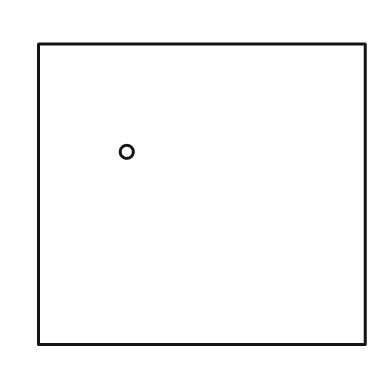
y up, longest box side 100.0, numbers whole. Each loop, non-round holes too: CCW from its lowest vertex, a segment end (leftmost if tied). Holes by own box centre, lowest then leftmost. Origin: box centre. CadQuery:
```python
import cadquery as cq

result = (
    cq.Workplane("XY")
    .moveTo(-50.0, -46.0)
    .lineTo(50.0, -46.0)
    .lineTo(50.0, 46.0)
    .lineTo(-50.0, 46.0)
    .close()
    .moveTo(-23.0, 13.0)
    .circle(2.0)
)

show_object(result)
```